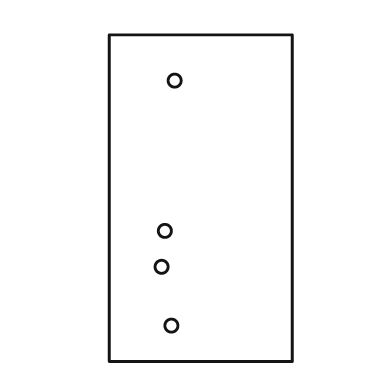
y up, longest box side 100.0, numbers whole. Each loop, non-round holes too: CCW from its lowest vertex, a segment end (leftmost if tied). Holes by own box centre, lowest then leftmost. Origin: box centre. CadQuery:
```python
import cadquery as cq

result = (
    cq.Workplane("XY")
    .moveTo(-28.0, -50.0)
    .lineTo(28.0, -50.0)
    .lineTo(28.0, 50.0)
    .lineTo(-28.0, 50.0)
    .close()
    .moveTo(-9.0, -39.0)
    .circle(2.0)
    .moveTo(-12.0, -21.0)
    .circle(2.0)
    .moveTo(-11.0, -10.0)
    .circle(2.0)
    .moveTo(-8.0, 36.0)
    .circle(2.0)
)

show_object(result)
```